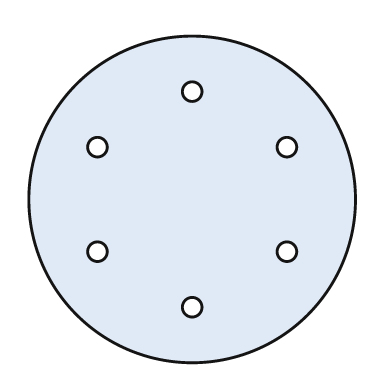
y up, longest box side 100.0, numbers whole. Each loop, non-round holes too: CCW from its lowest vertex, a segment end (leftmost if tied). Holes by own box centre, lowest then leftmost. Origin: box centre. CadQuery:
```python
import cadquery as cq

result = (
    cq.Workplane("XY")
    .moveTo(0.0, 0.0)
    .circle(50.0)
    .moveTo(0.0, -33.0)
    .circle(3.0)
    .moveTo(-29.0, -16.0)
    .circle(3.0)
    .moveTo(29.0, -16.0)
    .circle(3.0)
    .moveTo(-29.0, 16.0)
    .circle(3.0)
    .moveTo(29.0, 16.0)
    .circle(3.0)
    .moveTo(0.0, 33.0)
    .circle(3.0)
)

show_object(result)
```